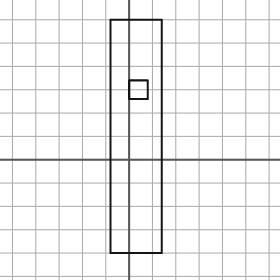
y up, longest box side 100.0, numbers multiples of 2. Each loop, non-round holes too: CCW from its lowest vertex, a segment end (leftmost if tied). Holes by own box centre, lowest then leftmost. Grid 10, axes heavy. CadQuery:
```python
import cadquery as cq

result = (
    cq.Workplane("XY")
    .moveTo(-8.0, -40.0)
    .lineTo(14.0, -40.0)
    .lineTo(14.0, 60.0)
    .lineTo(-8.0, 60.0)
    .close()
    .moveTo(0.0, 26.0)
    .lineTo(8.0, 26.0)
    .lineTo(8.0, 34.0)
    .lineTo(0.0, 34.0)
    .close()
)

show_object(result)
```